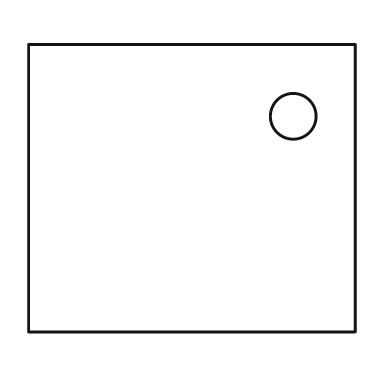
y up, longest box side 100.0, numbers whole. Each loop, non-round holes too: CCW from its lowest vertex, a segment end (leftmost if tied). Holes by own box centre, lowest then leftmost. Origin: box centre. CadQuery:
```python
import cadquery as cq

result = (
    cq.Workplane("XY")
    .moveTo(-50.0, -44.0)
    .lineTo(50.0, -44.0)
    .lineTo(50.0, 44.0)
    .lineTo(-50.0, 44.0)
    .close()
    .moveTo(31.0, 22.0)
    .circle(7.0)
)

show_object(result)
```